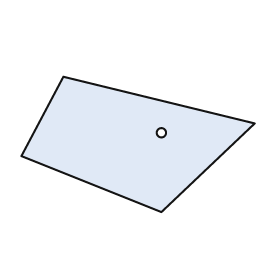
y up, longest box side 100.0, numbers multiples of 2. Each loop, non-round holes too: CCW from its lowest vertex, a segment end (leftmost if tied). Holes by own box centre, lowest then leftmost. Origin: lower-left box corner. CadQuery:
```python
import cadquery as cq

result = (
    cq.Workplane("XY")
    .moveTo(60.0, 0.0)
    .lineTo(100.0, 38.0)
    .lineTo(18.0, 58.0)
    .lineTo(0.0, 24.0)
    .close()
    .moveTo(60.0, 34.0)
    .circle(2.0)
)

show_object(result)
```